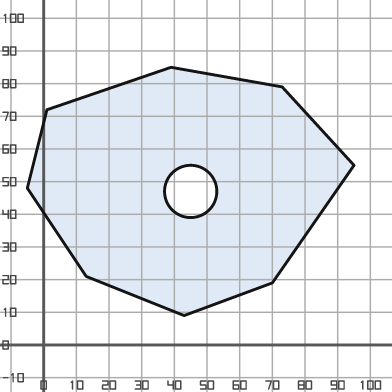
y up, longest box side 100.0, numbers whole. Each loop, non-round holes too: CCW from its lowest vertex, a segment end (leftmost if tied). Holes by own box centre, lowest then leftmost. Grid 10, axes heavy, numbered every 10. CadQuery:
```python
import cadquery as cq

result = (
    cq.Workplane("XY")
    .moveTo(43.0, 9.0)
    .lineTo(70.0, 19.0)
    .lineTo(95.0, 55.0)
    .lineTo(73.0, 79.0)
    .lineTo(39.0, 85.0)
    .lineTo(1.0, 72.0)
    .lineTo(-5.0, 48.0)
    .lineTo(13.0, 21.0)
    .close()
    .moveTo(45.0, 47.0)
    .circle(8.0)
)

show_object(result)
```